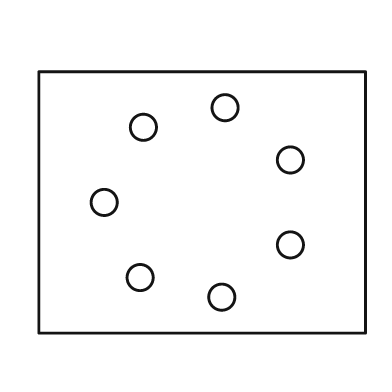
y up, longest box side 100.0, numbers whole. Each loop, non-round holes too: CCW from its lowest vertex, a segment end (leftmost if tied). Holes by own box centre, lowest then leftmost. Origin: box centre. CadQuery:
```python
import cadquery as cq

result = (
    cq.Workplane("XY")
    .moveTo(-50.0, -40.0)
    .lineTo(50.0, -40.0)
    .lineTo(50.0, 40.0)
    .lineTo(-50.0, 40.0)
    .close()
    .moveTo(6.0, -29.0)
    .circle(4.0)
    .moveTo(-19.0, -23.0)
    .circle(4.0)
    .moveTo(27.0, -13.0)
    .circle(4.0)
    .moveTo(-30.0, 0.0)
    .circle(4.0)
    .moveTo(27.0, 13.0)
    .circle(4.0)
    .moveTo(-18.0, 23.0)
    .circle(4.0)
    .moveTo(7.0, 29.0)
    .circle(4.0)
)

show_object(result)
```